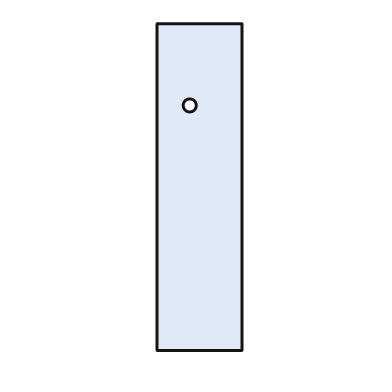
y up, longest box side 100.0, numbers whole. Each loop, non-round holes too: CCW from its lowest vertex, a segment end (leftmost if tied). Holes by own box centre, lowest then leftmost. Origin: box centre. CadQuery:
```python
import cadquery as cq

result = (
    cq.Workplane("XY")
    .moveTo(-13.0, -50.0)
    .lineTo(13.0, -50.0)
    .lineTo(13.0, 50.0)
    .lineTo(-13.0, 50.0)
    .close()
    .moveTo(-3.0, 25.0)
    .circle(2.0)
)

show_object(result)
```